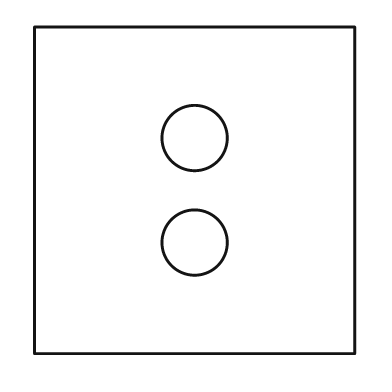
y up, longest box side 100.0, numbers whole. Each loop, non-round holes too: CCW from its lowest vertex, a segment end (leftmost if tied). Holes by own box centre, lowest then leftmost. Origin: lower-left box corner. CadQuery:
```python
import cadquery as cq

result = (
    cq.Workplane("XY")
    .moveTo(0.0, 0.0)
    .lineTo(98.0, 0.0)
    .lineTo(98.0, 100.0)
    .lineTo(0.0, 100.0)
    .close()
    .moveTo(49.0, 34.0)
    .circle(10.0)
    .moveTo(49.0, 66.0)
    .circle(10.0)
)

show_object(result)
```